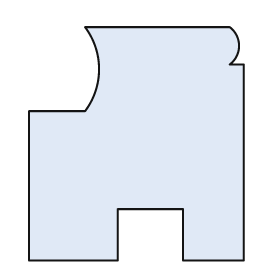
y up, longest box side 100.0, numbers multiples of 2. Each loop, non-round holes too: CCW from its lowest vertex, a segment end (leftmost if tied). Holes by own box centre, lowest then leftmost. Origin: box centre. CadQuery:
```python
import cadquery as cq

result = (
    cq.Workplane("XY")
    .moveTo(-46.0, -50.0)
    .lineTo(-8.0, -50.0)
    .lineTo(-8.0, -28.0)
    .lineTo(20.0, -28.0)
    .lineTo(20.0, -50.0)
    .lineTo(46.0, -50.0)
    .lineTo(46.0, 34.0)
    .lineTo(40.0, 34.0)
    .threePointArc((44.0, 42.0), (40.0, 50.0))
    .lineTo(-22.0, 50.0)
    .threePointArc((-16.0, 32.0), (-22.0, 14.0))
    .lineTo(-46.0, 14.0)
    .close()
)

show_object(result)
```